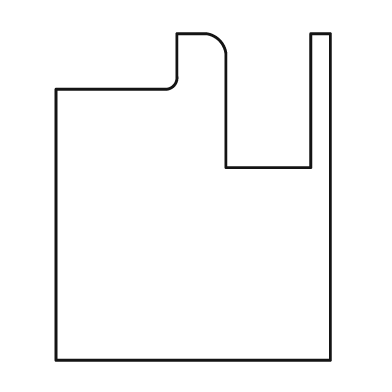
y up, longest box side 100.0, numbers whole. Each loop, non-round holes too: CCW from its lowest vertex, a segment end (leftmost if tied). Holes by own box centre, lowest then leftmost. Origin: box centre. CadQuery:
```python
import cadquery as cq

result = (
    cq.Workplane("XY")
    .moveTo(-42.0, -50.0)
    .lineTo(42.0, -50.0)
    .lineTo(42.0, 50.0)
    .lineTo(36.0, 50.0)
    .lineTo(36.0, 9.0)
    .lineTo(10.0, 9.0)
    .lineTo(10.0, 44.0)
    .threePointArc((8.0, 48.0), (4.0, 50.0))
    .lineTo(-5.0, 50.0)
    .lineTo(-5.0, 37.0)
    .threePointArc((-6.0, 34.0), (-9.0, 33.0))
    .lineTo(-42.0, 33.0)
    .close()
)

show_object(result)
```